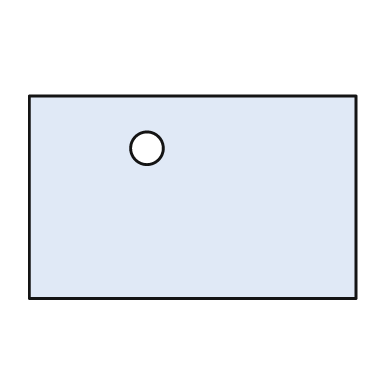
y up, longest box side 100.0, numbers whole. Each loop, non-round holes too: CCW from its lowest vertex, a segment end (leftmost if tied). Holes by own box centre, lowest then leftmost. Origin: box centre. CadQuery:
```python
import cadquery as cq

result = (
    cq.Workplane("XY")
    .moveTo(-50.0, -31.0)
    .lineTo(50.0, -31.0)
    .lineTo(50.0, 31.0)
    .lineTo(-50.0, 31.0)
    .close()
    .moveTo(-14.0, 15.0)
    .circle(5.0)
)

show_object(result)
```